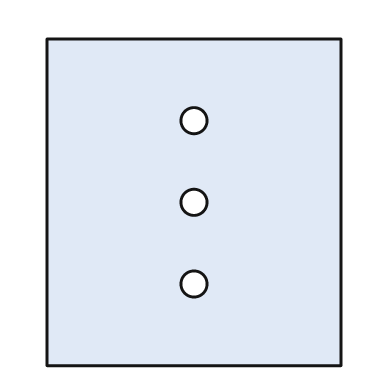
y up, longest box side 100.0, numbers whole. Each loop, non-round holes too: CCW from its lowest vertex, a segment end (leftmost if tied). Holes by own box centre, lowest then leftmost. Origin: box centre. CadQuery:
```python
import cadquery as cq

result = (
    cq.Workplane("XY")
    .moveTo(-45.0, -50.0)
    .lineTo(45.0, -50.0)
    .lineTo(45.0, 50.0)
    .lineTo(-45.0, 50.0)
    .close()
    .moveTo(0.0, -25.0)
    .circle(4.0)
    .moveTo(0.0, 0.0)
    .circle(4.0)
    .moveTo(0.0, 25.0)
    .circle(4.0)
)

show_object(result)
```